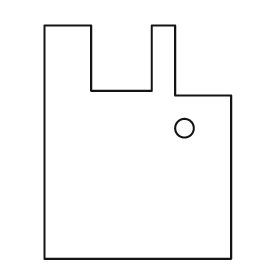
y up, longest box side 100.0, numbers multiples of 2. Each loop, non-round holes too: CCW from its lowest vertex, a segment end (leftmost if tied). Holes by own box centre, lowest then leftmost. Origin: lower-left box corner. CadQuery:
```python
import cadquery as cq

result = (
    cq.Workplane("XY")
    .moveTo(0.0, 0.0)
    .lineTo(80.0, 0.0)
    .lineTo(80.0, 70.0)
    .lineTo(56.0, 70.0)
    .lineTo(56.0, 100.0)
    .lineTo(46.0, 100.0)
    .lineTo(46.0, 72.0)
    .lineTo(20.0, 72.0)
    .lineTo(20.0, 100.0)
    .lineTo(0.0, 100.0)
    .close()
    .moveTo(60.0, 56.0)
    .circle(4.0)
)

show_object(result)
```